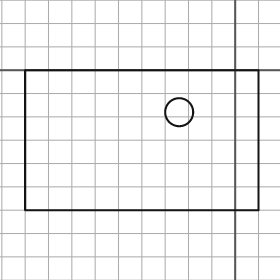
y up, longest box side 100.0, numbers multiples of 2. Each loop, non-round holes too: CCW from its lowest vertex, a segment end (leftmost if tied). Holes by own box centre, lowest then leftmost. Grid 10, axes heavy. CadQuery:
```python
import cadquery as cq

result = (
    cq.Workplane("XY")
    .moveTo(-90.0, -60.0)
    .lineTo(10.0, -60.0)
    .lineTo(10.0, 0.0)
    .lineTo(-90.0, 0.0)
    .close()
    .moveTo(-24.0, -18.0)
    .circle(6.0)
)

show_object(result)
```